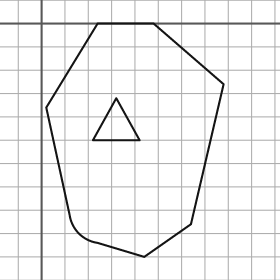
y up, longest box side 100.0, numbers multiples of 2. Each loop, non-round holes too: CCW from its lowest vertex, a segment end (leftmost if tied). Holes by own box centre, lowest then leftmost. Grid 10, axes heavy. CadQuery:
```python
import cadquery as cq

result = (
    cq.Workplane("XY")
    .moveTo(44.0, -100.0)
    .lineTo(64.0, -86.0)
    .lineTo(78.0, -26.0)
    .lineTo(48.0, 0.0)
    .lineTo(24.0, 0.0)
    .lineTo(2.0, -36.0)
    .lineTo(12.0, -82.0)
    .threePointArc((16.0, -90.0), (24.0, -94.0))
    .close()
    .moveTo(22.0, -50.0)
    .lineTo(42.0, -50.0)
    .lineTo(32.0, -32.0)
    .close()
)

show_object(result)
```